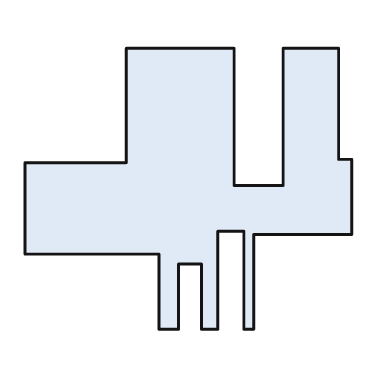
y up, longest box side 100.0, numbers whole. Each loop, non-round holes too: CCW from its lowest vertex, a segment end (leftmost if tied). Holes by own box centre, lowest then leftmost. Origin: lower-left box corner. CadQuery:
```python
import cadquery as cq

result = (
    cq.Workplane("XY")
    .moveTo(41.0, 0.0)
    .lineTo(47.0, 0.0)
    .lineTo(47.0, 20.0)
    .lineTo(54.0, 20.0)
    .lineTo(54.0, 0.0)
    .lineTo(59.0, 0.0)
    .lineTo(59.0, 30.0)
    .lineTo(67.0, 30.0)
    .lineTo(67.0, 0.0)
    .lineTo(70.0, 0.0)
    .lineTo(70.0, 29.0)
    .lineTo(100.0, 29.0)
    .lineTo(100.0, 52.0)
    .lineTo(96.0, 52.0)
    .lineTo(96.0, 86.0)
    .lineTo(79.0, 86.0)
    .lineTo(79.0, 44.0)
    .lineTo(64.0, 44.0)
    .lineTo(64.0, 86.0)
    .lineTo(31.0, 86.0)
    .lineTo(31.0, 51.0)
    .lineTo(0.0, 51.0)
    .lineTo(0.0, 23.0)
    .lineTo(41.0, 23.0)
    .close()
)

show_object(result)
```